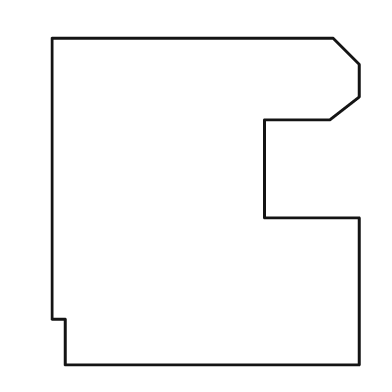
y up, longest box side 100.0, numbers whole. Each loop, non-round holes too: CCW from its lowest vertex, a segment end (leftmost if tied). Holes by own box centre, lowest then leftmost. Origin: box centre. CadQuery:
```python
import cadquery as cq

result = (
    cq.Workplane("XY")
    .moveTo(-43.0, -50.0)
    .lineTo(47.0, -50.0)
    .lineTo(47.0, -5.0)
    .lineTo(18.0, -5.0)
    .lineTo(18.0, 25.0)
    .lineTo(38.0, 25.0)
    .lineTo(47.0, 32.0)
    .lineTo(47.0, 42.0)
    .lineTo(39.0, 50.0)
    .lineTo(-47.0, 50.0)
    .lineTo(-47.0, -36.0)
    .lineTo(-43.0, -36.0)
    .close()
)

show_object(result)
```